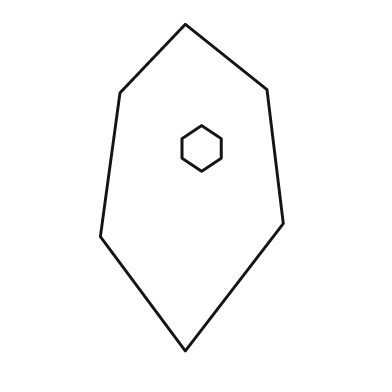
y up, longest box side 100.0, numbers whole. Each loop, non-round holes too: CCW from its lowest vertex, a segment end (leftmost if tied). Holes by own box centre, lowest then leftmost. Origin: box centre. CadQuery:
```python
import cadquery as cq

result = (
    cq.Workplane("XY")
    .moveTo(-2.0, -50.0)
    .lineTo(28.0, -11.0)
    .lineTo(23.0, 30.0)
    .lineTo(-2.0, 50.0)
    .lineTo(-22.0, 29.0)
    .lineTo(-28.0, -15.0)
    .close()
    .moveTo(3.0, 5.0)
    .lineTo(9.0, 9.0)
    .lineTo(9.0, 15.0)
    .lineTo(3.0, 19.0)
    .lineTo(-3.0, 15.0)
    .lineTo(-3.0, 9.0)
    .close()
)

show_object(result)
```